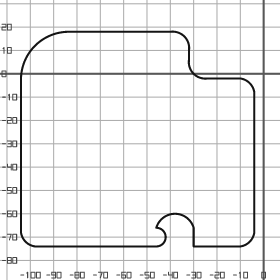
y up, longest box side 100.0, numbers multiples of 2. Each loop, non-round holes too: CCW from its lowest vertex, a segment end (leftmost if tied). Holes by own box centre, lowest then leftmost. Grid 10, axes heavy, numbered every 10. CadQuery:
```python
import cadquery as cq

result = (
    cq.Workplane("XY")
    .moveTo(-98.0, -74.0)
    .lineTo(-46.0, -74.0)
    .threePointArc((-42.0, -70.0), (-46.0, -66.0))
    .threePointArc((-38.0, -60.0), (-30.0, -66.0))
    .lineTo(-30.0, -74.0)
    .lineTo(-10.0, -74.0)
    .threePointArc((-6.0, -72.0), (-4.0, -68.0))
    .lineTo(-4.0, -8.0)
    .threePointArc((-6.0, -4.0), (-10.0, -2.0))
    .lineTo(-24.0, -2.0)
    .threePointArc((-30.0, 0.0), (-32.0, 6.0))
    .lineTo(-32.0, 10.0)
    .threePointArc((-34.0, 16.0), (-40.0, 18.0))
    .lineTo(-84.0, 18.0)
    .threePointArc((-98.0, 12.0), (-104.0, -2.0))
    .lineTo(-104.0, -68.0)
    .threePointArc((-102.0, -72.0), (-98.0, -74.0))
    .close()
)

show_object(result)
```